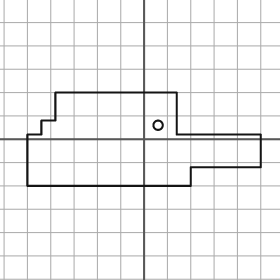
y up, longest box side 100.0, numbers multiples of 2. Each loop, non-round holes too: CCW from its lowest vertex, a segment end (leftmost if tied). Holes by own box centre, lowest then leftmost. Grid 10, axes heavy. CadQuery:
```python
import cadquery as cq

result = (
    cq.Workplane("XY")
    .moveTo(-50.0, -20.0)
    .lineTo(20.0, -20.0)
    .lineTo(20.0, -12.0)
    .lineTo(50.0, -12.0)
    .lineTo(50.0, 2.0)
    .lineTo(14.0, 2.0)
    .lineTo(14.0, 20.0)
    .lineTo(-38.0, 20.0)
    .lineTo(-38.0, 8.0)
    .lineTo(-44.0, 8.0)
    .lineTo(-44.0, 2.0)
    .lineTo(-50.0, 2.0)
    .close()
    .moveTo(6.0, 6.0)
    .circle(2.0)
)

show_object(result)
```